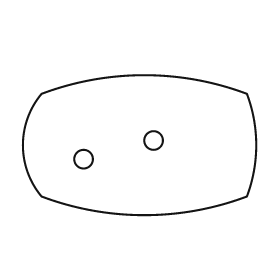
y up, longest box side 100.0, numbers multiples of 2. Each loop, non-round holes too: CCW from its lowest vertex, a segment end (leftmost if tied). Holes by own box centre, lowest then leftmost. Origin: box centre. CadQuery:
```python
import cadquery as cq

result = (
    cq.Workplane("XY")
    .moveTo(-42.0, -22.0)
    .threePointArc((2.0, -30.0), (46.0, -22.0))
    .threePointArc((50.0, 0.0), (46.0, 22.0))
    .threePointArc((2.0, 30.0), (-42.0, 22.0))
    .threePointArc((-50.0, 0.0), (-42.0, -22.0))
    .close()
    .moveTo(-24.0, -6.0)
    .circle(4.0)
    .moveTo(6.0, 2.0)
    .circle(4.0)
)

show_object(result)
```